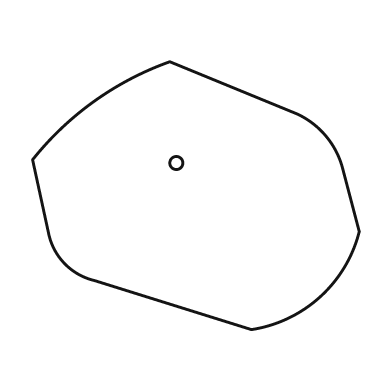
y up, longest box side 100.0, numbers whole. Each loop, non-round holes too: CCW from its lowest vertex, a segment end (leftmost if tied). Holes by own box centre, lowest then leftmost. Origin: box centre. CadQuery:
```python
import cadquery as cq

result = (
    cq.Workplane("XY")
    .moveTo(17.0, -41.0)
    .threePointArc((38.0, -31.0), (50.0, -11.0))
    .lineTo(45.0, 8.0)
    .threePointArc((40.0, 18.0), (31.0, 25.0))
    .lineTo(-8.0, 41.0)
    .threePointArc((-31.0, 29.0), (-50.0, 11.0))
    .lineTo(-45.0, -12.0)
    .threePointArc((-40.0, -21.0), (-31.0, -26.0))
    .close()
    .moveTo(-6.0, 10.0)
    .circle(2.0)
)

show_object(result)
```